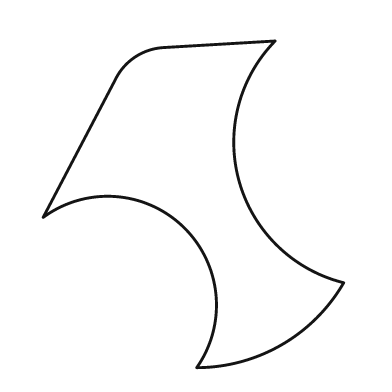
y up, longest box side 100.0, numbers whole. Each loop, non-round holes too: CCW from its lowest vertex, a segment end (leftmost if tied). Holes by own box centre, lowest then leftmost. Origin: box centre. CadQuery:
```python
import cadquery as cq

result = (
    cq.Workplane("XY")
    .moveTo(1.0, -50.0)
    .threePointArc((27.0, -43.0), (46.0, -24.0))
    .threePointArc((14.0, 7.0), (25.0, 50.0))
    .lineTo(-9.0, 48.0)
    .threePointArc((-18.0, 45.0), (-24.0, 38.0))
    .lineTo(-46.0, -4.0)
    .threePointArc((-3.0, -7.0), (1.0, -50.0))
    .close()
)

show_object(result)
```